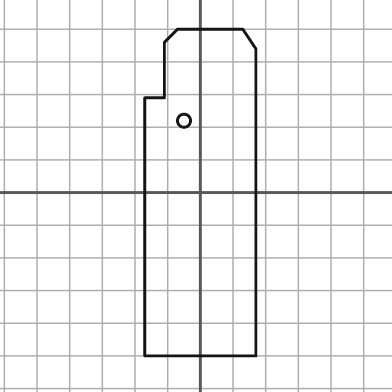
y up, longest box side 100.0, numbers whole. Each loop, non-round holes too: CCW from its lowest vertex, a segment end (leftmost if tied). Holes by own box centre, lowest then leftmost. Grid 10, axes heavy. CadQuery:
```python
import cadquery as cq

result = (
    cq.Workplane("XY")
    .moveTo(-17.0, -50.0)
    .lineTo(17.0, -50.0)
    .lineTo(17.0, 44.0)
    .lineTo(13.0, 50.0)
    .lineTo(-7.0, 50.0)
    .lineTo(-11.0, 46.0)
    .lineTo(-11.0, 29.0)
    .lineTo(-17.0, 29.0)
    .close()
    .moveTo(-5.0, 22.0)
    .circle(2.0)
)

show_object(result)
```